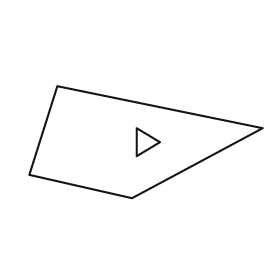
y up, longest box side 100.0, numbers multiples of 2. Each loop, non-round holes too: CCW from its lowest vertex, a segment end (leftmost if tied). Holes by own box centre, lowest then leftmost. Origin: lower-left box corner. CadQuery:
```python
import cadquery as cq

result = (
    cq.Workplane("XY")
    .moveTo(44.0, 0.0)
    .lineTo(100.0, 30.0)
    .lineTo(12.0, 48.0)
    .lineTo(0.0, 10.0)
    .close()
    .moveTo(46.0, 18.0)
    .lineTo(56.0, 24.0)
    .lineTo(46.0, 30.0)
    .close()
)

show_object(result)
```